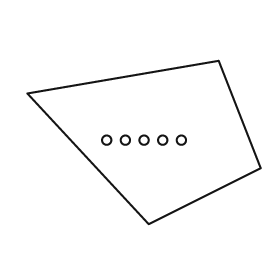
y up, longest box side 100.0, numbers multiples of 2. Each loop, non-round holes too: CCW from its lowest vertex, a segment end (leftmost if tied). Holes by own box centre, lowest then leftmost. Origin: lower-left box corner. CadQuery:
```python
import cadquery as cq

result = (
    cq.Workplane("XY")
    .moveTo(52.0, 0.0)
    .lineTo(100.0, 24.0)
    .lineTo(82.0, 70.0)
    .lineTo(0.0, 56.0)
    .close()
    .moveTo(34.0, 36.0)
    .circle(2.0)
    .moveTo(42.0, 36.0)
    .circle(2.0)
    .moveTo(50.0, 36.0)
    .circle(2.0)
    .moveTo(58.0, 36.0)
    .circle(2.0)
    .moveTo(66.0, 36.0)
    .circle(2.0)
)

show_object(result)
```